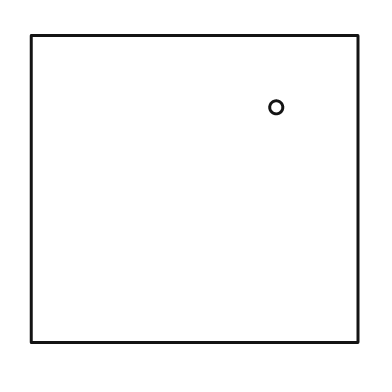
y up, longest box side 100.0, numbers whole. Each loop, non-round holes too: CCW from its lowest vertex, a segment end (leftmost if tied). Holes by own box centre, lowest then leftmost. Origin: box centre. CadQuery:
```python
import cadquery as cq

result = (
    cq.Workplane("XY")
    .moveTo(-50.0, -47.0)
    .lineTo(50.0, -47.0)
    .lineTo(50.0, 47.0)
    .lineTo(-50.0, 47.0)
    .close()
    .moveTo(25.0, 25.0)
    .circle(2.0)
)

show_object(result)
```